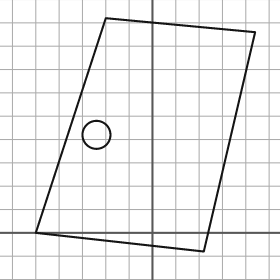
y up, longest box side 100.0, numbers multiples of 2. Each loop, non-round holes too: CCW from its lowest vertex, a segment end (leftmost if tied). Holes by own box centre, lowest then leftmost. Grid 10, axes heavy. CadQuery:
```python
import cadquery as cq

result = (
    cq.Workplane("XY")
    .moveTo(22.0, -8.0)
    .lineTo(44.0, 86.0)
    .lineTo(-20.0, 92.0)
    .lineTo(-50.0, 0.0)
    .close()
    .moveTo(-24.0, 42.0)
    .circle(6.0)
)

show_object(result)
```